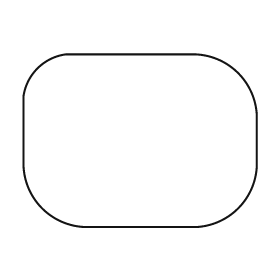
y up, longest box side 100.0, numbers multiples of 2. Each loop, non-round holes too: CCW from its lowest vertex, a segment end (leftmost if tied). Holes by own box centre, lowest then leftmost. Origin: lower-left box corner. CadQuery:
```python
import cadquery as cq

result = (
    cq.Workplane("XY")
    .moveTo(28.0, 0.0)
    .lineTo(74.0, 0.0)
    .threePointArc((92.0, 8.0), (100.0, 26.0))
    .lineTo(100.0, 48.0)
    .threePointArc((92.0, 66.0), (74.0, 74.0))
    .lineTo(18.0, 74.0)
    .threePointArc((6.0, 68.0), (0.0, 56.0))
    .lineTo(0.0, 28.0)
    .threePointArc((8.0, 8.0), (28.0, 0.0))
    .close()
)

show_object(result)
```